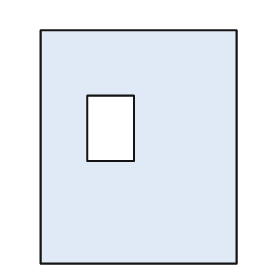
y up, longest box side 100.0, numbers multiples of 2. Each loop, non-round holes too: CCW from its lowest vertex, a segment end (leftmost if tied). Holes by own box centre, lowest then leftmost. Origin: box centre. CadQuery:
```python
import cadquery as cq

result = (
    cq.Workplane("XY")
    .moveTo(-42.0, -50.0)
    .lineTo(42.0, -50.0)
    .lineTo(42.0, 50.0)
    .lineTo(-42.0, 50.0)
    .close()
    .moveTo(-22.0, -6.0)
    .lineTo(-2.0, -6.0)
    .lineTo(-2.0, 22.0)
    .lineTo(-22.0, 22.0)
    .close()
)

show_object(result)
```